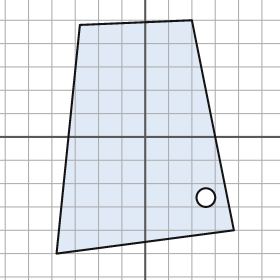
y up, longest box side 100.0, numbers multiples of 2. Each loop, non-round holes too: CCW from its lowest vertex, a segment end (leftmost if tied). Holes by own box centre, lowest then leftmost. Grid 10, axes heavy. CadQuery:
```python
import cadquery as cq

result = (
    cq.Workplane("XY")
    .moveTo(-38.0, -50.0)
    .lineTo(38.0, -40.0)
    .lineTo(20.0, 50.0)
    .lineTo(-28.0, 48.0)
    .close()
    .moveTo(26.0, -26.0)
    .circle(4.0)
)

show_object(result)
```